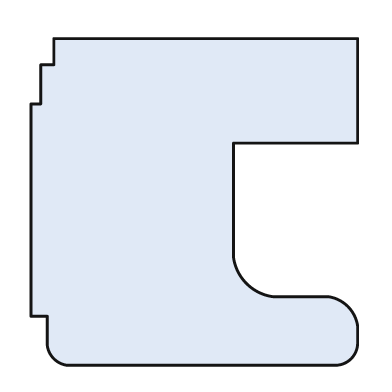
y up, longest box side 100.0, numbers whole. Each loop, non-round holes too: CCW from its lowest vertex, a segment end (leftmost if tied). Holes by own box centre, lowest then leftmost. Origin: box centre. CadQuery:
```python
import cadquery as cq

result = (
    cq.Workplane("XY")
    .moveTo(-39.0, -50.0)
    .lineTo(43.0, -50.0)
    .threePointArc((48.0, -48.0), (50.0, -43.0))
    .lineTo(50.0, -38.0)
    .threePointArc((47.0, -32.0), (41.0, -29.0))
    .lineTo(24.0, -29.0)
    .threePointArc((16.0, -25.0), (12.0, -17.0))
    .lineTo(12.0, 18.0)
    .lineTo(50.0, 18.0)
    .lineTo(50.0, 50.0)
    .lineTo(-43.0, 50.0)
    .lineTo(-43.0, 42.0)
    .lineTo(-47.0, 42.0)
    .lineTo(-47.0, 30.0)
    .lineTo(-50.0, 30.0)
    .lineTo(-50.0, -35.0)
    .lineTo(-45.0, -35.0)
    .lineTo(-45.0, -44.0)
    .threePointArc((-43.0, -48.0), (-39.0, -50.0))
    .close()
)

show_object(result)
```